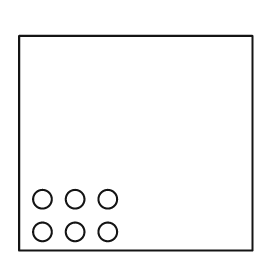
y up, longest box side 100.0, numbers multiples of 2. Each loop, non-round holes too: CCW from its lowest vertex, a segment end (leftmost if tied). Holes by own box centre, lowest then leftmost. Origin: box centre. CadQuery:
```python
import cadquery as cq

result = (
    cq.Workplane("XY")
    .moveTo(-50.0, -46.0)
    .lineTo(50.0, -46.0)
    .lineTo(50.0, 46.0)
    .lineTo(-50.0, 46.0)
    .close()
    .moveTo(-40.0, -38.0)
    .circle(4.0)
    .moveTo(-26.0, -38.0)
    .circle(4.0)
    .moveTo(-12.0, -38.0)
    .circle(4.0)
    .moveTo(-40.0, -24.0)
    .circle(4.0)
    .moveTo(-26.0, -24.0)
    .circle(4.0)
    .moveTo(-12.0, -24.0)
    .circle(4.0)
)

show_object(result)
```